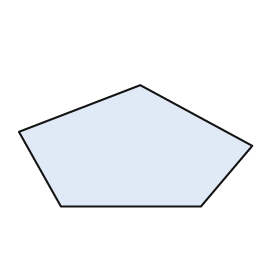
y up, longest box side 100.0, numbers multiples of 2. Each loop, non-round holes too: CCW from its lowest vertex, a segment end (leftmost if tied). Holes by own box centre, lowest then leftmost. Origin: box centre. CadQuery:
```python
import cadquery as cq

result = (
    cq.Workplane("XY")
    .moveTo(-32.0, -26.0)
    .lineTo(28.0, -26.0)
    .lineTo(50.0, 0.0)
    .lineTo(2.0, 26.0)
    .lineTo(-50.0, 6.0)
    .close()
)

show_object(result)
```